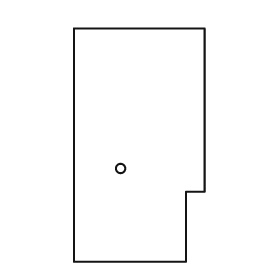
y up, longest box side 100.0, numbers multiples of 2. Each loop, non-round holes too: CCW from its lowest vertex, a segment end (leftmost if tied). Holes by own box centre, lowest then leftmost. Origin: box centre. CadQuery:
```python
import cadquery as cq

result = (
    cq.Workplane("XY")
    .moveTo(-28.0, -50.0)
    .lineTo(20.0, -50.0)
    .lineTo(20.0, -20.0)
    .lineTo(28.0, -20.0)
    .lineTo(28.0, 50.0)
    .lineTo(-28.0, 50.0)
    .close()
    .moveTo(-8.0, -10.0)
    .circle(2.0)
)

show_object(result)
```